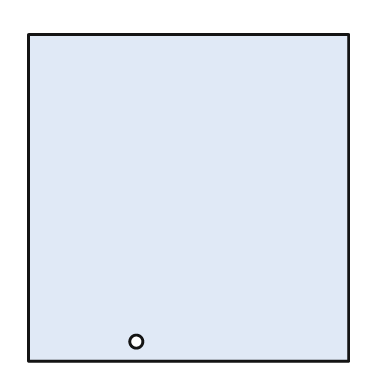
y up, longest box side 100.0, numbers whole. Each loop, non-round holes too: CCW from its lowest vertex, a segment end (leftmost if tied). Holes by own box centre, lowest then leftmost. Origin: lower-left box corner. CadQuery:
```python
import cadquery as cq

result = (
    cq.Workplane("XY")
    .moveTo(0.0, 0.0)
    .lineTo(98.0, 0.0)
    .lineTo(98.0, 100.0)
    .lineTo(0.0, 100.0)
    .close()
    .moveTo(33.0, 6.0)
    .circle(2.0)
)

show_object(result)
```